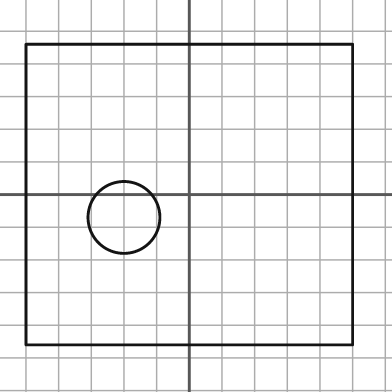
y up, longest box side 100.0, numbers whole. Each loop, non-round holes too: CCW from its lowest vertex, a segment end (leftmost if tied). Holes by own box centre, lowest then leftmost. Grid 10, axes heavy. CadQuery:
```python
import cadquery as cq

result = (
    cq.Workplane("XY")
    .moveTo(-50.0, -46.0)
    .lineTo(50.0, -46.0)
    .lineTo(50.0, 46.0)
    .lineTo(-50.0, 46.0)
    .close()
    .moveTo(-20.0, -7.0)
    .circle(11.0)
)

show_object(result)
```